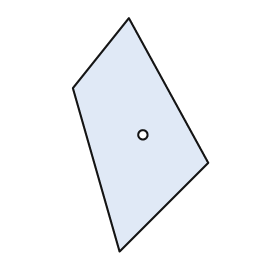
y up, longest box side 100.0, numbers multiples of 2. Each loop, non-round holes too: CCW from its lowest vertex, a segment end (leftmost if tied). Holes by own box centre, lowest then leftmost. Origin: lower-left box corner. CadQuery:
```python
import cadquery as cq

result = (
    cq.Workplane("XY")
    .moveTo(20.0, 0.0)
    .lineTo(58.0, 38.0)
    .lineTo(24.0, 100.0)
    .lineTo(0.0, 70.0)
    .close()
    .moveTo(30.0, 50.0)
    .circle(2.0)
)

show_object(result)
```